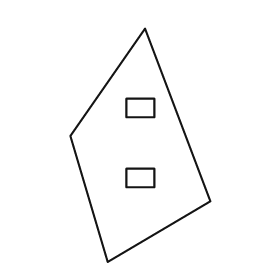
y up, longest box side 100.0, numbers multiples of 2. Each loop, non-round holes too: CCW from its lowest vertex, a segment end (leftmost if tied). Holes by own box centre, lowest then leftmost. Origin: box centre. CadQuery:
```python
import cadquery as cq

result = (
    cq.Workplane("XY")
    .moveTo(-14.0, -50.0)
    .lineTo(30.0, -24.0)
    .lineTo(2.0, 50.0)
    .lineTo(-30.0, 4.0)
    .close()
    .moveTo(-6.0, -18.0)
    .lineTo(6.0, -18.0)
    .lineTo(6.0, -10.0)
    .lineTo(-6.0, -10.0)
    .close()
    .moveTo(-6.0, 12.0)
    .lineTo(6.0, 12.0)
    .lineTo(6.0, 20.0)
    .lineTo(-6.0, 20.0)
    .close()
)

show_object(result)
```